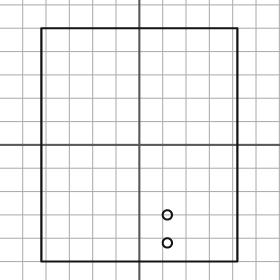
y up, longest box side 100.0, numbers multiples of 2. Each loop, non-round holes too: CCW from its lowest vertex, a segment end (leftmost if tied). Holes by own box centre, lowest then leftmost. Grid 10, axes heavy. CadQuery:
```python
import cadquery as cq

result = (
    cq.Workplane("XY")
    .moveTo(-42.0, -50.0)
    .lineTo(42.0, -50.0)
    .lineTo(42.0, 50.0)
    .lineTo(-42.0, 50.0)
    .close()
    .moveTo(12.0, -42.0)
    .circle(2.0)
    .moveTo(12.0, -30.0)
    .circle(2.0)
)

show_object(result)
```